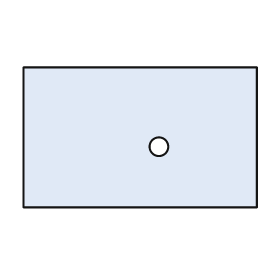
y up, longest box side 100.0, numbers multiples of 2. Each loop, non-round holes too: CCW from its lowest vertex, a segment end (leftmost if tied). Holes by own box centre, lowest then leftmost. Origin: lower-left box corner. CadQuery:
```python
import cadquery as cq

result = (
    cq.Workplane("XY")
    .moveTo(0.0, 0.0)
    .lineTo(100.0, 0.0)
    .lineTo(100.0, 60.0)
    .lineTo(0.0, 60.0)
    .close()
    .moveTo(58.0, 26.0)
    .circle(4.0)
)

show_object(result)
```